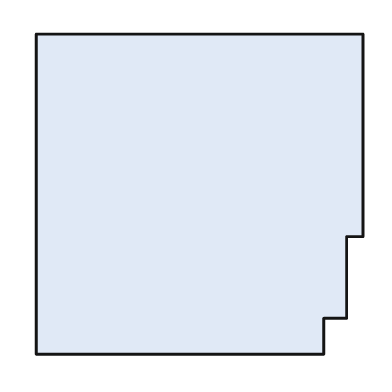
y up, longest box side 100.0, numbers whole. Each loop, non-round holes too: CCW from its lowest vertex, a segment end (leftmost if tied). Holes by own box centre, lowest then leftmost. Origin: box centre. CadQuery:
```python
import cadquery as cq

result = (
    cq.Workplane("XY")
    .moveTo(-50.0, -49.0)
    .lineTo(38.0, -49.0)
    .lineTo(38.0, -38.0)
    .lineTo(45.0, -38.0)
    .lineTo(45.0, -13.0)
    .lineTo(50.0, -13.0)
    .lineTo(50.0, 49.0)
    .lineTo(-50.0, 49.0)
    .close()
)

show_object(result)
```